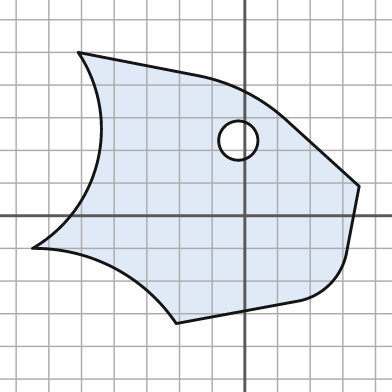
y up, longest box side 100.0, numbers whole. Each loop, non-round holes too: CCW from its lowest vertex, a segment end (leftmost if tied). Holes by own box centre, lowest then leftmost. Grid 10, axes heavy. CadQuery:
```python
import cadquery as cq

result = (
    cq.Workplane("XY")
    .moveTo(-21.0, -33.0)
    .lineTo(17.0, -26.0)
    .threePointArc((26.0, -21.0), (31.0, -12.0))
    .lineTo(35.0, 9.0)
    .lineTo(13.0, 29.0)
    .threePointArc((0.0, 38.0), (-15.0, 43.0))
    .lineTo(-51.0, 50.0)
    .threePointArc((-45.0, 17.0), (-65.0, -10.0))
    .threePointArc((-40.0, -16.0), (-21.0, -33.0))
    .close()
    .moveTo(-2.0, 23.0)
    .circle(6.0)
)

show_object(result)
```